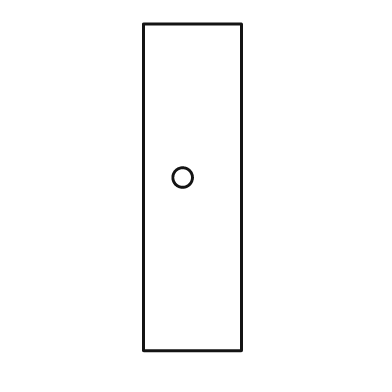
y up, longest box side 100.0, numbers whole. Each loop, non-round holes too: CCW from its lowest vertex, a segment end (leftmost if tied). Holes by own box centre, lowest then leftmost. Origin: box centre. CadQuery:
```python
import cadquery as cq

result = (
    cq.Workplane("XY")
    .moveTo(-15.0, -50.0)
    .lineTo(15.0, -50.0)
    .lineTo(15.0, 50.0)
    .lineTo(-15.0, 50.0)
    .close()
    .moveTo(-3.0, 3.0)
    .circle(3.0)
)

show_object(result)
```